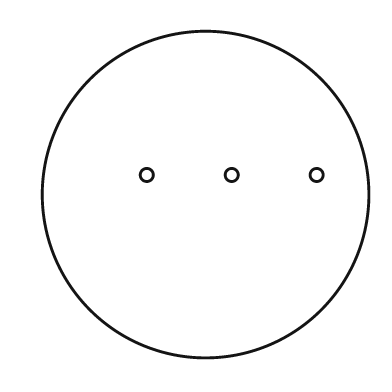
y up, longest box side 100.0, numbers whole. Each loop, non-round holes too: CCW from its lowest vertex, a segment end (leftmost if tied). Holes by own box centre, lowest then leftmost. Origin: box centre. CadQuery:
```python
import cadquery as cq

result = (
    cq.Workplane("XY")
    .moveTo(0.0, 0.0)
    .circle(50.0)
    .moveTo(-18.0, 6.0)
    .circle(2.0)
    .moveTo(8.0, 6.0)
    .circle(2.0)
    .moveTo(34.0, 6.0)
    .circle(2.0)
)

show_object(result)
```